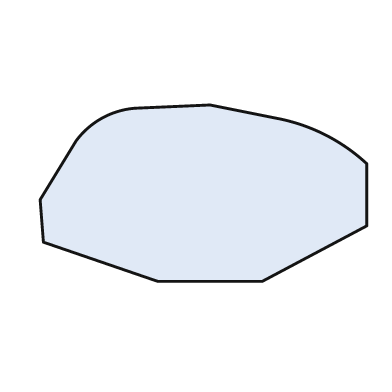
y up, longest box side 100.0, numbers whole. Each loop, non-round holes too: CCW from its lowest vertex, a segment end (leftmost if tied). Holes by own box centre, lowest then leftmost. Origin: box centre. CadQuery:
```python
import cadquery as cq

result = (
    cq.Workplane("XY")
    .moveTo(-14.0, -27.0)
    .lineTo(18.0, -27.0)
    .lineTo(50.0, -10.0)
    .lineTo(50.0, 9.0)
    .threePointArc((37.0, 18.0), (22.0, 23.0))
    .lineTo(2.0, 27.0)
    .lineTo(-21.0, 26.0)
    .threePointArc((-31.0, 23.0), (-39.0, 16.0))
    .lineTo(-50.0, -2.0)
    .lineTo(-49.0, -15.0)
    .close()
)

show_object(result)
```